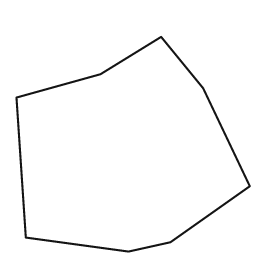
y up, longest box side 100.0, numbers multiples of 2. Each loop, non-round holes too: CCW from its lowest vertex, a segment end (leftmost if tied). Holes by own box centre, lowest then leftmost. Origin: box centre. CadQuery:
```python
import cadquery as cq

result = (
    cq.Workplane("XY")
    .moveTo(-2.0, -46.0)
    .lineTo(16.0, -42.0)
    .lineTo(50.0, -18.0)
    .lineTo(30.0, 24.0)
    .lineTo(12.0, 46.0)
    .lineTo(-14.0, 30.0)
    .lineTo(-50.0, 20.0)
    .lineTo(-46.0, -40.0)
    .close()
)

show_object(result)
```